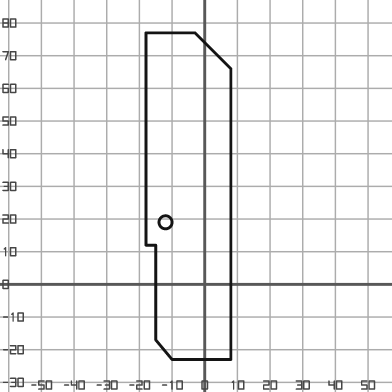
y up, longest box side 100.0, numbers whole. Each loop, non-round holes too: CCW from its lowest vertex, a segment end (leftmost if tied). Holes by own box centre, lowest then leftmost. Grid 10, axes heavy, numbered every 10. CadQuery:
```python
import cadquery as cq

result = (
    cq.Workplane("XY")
    .moveTo(-10.0, -23.0)
    .lineTo(8.0, -23.0)
    .lineTo(8.0, 66.0)
    .lineTo(-3.0, 77.0)
    .lineTo(-18.0, 77.0)
    .lineTo(-18.0, 12.0)
    .lineTo(-15.0, 12.0)
    .lineTo(-15.0, -17.0)
    .close()
    .moveTo(-12.0, 19.0)
    .circle(2.0)
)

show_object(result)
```